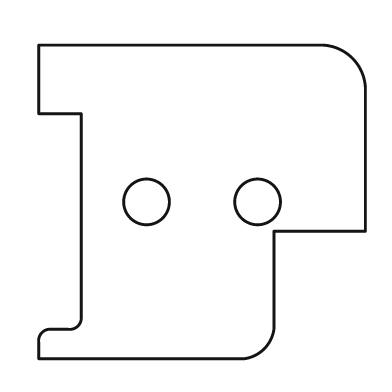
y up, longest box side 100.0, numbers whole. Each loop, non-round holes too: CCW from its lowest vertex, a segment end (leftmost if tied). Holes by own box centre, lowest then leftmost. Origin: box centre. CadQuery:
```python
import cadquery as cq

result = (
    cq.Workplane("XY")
    .moveTo(-50.0, -48.0)
    .lineTo(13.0, -48.0)
    .threePointArc((19.0, -45.0), (22.0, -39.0))
    .lineTo(22.0, -9.0)
    .lineTo(50.0, -9.0)
    .lineTo(50.0, 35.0)
    .threePointArc((46.0, 44.0), (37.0, 48.0))
    .lineTo(-50.0, 48.0)
    .lineTo(-50.0, 27.0)
    .lineTo(-37.0, 27.0)
    .lineTo(-37.0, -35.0)
    .threePointArc((-38.0, -38.0), (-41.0, -39.0))
    .lineTo(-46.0, -39.0)
    .threePointArc((-49.0, -40.0), (-50.0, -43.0))
    .close()
    .moveTo(-17.0, 0.0)
    .circle(7.0)
    .moveTo(17.0, 0.0)
    .circle(7.0)
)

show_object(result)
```